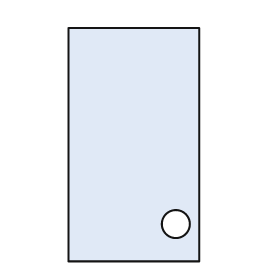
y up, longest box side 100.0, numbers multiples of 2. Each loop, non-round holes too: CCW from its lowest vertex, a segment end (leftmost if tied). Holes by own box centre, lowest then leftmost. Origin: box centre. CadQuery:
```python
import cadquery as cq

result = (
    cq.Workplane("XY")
    .moveTo(-28.0, -50.0)
    .lineTo(28.0, -50.0)
    .lineTo(28.0, 50.0)
    .lineTo(-28.0, 50.0)
    .close()
    .moveTo(18.0, -34.0)
    .circle(6.0)
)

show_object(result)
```